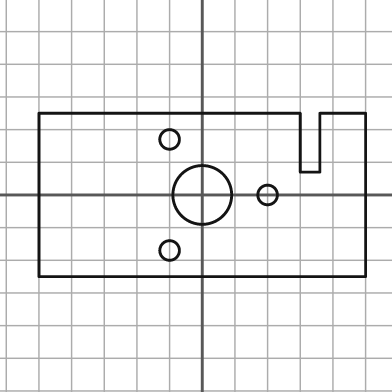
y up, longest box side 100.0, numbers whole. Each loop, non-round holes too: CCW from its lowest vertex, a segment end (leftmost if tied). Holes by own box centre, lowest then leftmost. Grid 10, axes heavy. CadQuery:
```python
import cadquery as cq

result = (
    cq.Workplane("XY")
    .moveTo(-50.0, -25.0)
    .lineTo(50.0, -25.0)
    .lineTo(50.0, 25.0)
    .lineTo(36.0, 25.0)
    .lineTo(36.0, 7.0)
    .lineTo(30.0, 7.0)
    .lineTo(30.0, 25.0)
    .lineTo(-50.0, 25.0)
    .close()
    .moveTo(-10.0, -17.0)
    .circle(3.0)
    .moveTo(0.0, 0.0)
    .circle(9.0)
    .moveTo(20.0, 0.0)
    .circle(3.0)
    .moveTo(-10.0, 17.0)
    .circle(3.0)
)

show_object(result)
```